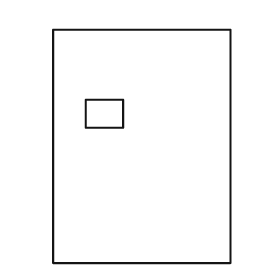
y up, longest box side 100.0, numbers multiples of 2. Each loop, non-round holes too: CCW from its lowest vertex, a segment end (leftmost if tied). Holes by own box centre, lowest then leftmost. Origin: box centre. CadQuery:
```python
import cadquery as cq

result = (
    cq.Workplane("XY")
    .moveTo(-38.0, -50.0)
    .lineTo(38.0, -50.0)
    .lineTo(38.0, 50.0)
    .lineTo(-38.0, 50.0)
    .close()
    .moveTo(-24.0, 8.0)
    .lineTo(-8.0, 8.0)
    .lineTo(-8.0, 20.0)
    .lineTo(-24.0, 20.0)
    .close()
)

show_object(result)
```